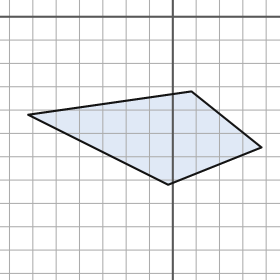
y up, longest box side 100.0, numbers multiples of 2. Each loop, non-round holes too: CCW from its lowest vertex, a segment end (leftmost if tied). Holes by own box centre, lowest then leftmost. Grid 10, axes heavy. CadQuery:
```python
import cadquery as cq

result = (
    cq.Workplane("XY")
    .moveTo(-2.0, -72.0)
    .lineTo(38.0, -56.0)
    .lineTo(8.0, -32.0)
    .lineTo(-62.0, -42.0)
    .close()
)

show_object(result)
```